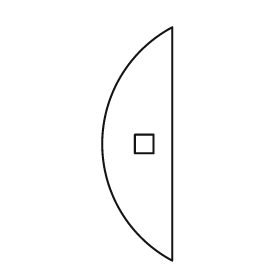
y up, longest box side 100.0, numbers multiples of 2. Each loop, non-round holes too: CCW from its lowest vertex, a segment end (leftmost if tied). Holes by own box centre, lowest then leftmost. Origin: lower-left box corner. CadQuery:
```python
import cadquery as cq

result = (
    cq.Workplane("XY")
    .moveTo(30.0, 0.0)
    .lineTo(30.0, 100.0)
    .threePointArc((0.0, 50.0), (30.0, 0.0))
    .close()
    .moveTo(14.0, 46.0)
    .lineTo(22.0, 46.0)
    .lineTo(22.0, 54.0)
    .lineTo(14.0, 54.0)
    .close()
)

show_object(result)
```